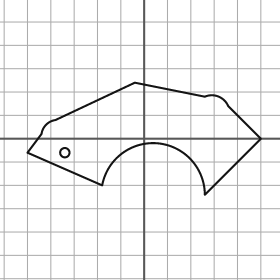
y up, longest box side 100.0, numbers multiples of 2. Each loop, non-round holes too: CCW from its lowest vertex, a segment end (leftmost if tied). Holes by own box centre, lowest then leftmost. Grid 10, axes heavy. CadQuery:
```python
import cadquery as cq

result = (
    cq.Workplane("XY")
    .moveTo(26.0, -24.0)
    .lineTo(50.0, 0.0)
    .lineTo(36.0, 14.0)
    .threePointArc((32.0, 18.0), (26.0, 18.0))
    .lineTo(-4.0, 24.0)
    .lineTo(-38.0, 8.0)
    .threePointArc((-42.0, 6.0), (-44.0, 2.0))
    .lineTo(-50.0, -6.0)
    .lineTo(-18.0, -20.0)
    .threePointArc((6.0, -2.0), (26.0, -24.0))
    .close()
    .moveTo(-34.0, -6.0)
    .circle(2.0)
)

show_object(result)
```